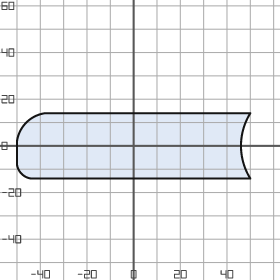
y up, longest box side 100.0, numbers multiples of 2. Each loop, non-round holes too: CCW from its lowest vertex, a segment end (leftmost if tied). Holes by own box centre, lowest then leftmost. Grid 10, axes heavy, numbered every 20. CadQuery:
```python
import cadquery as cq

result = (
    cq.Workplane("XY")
    .moveTo(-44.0, -14.0)
    .lineTo(50.0, -14.0)
    .threePointArc((46.0, 0.0), (50.0, 14.0))
    .lineTo(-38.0, 14.0)
    .threePointArc((-46.0, 10.0), (-50.0, 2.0))
    .lineTo(-50.0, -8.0)
    .threePointArc((-48.0, -12.0), (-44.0, -14.0))
    .close()
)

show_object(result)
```